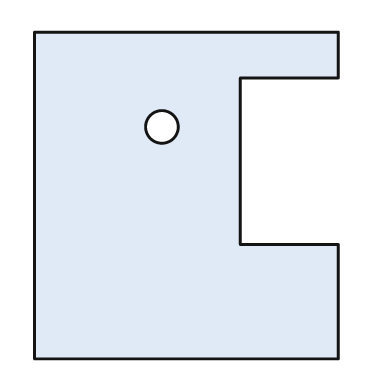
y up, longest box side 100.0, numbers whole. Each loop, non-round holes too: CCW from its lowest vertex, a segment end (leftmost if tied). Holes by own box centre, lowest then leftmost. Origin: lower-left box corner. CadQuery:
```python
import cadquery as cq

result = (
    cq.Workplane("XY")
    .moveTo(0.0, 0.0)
    .lineTo(93.0, 0.0)
    .lineTo(93.0, 35.0)
    .lineTo(63.0, 35.0)
    .lineTo(63.0, 86.0)
    .lineTo(93.0, 86.0)
    .lineTo(93.0, 100.0)
    .lineTo(0.0, 100.0)
    .close()
    .moveTo(39.0, 71.0)
    .circle(5.0)
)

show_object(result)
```